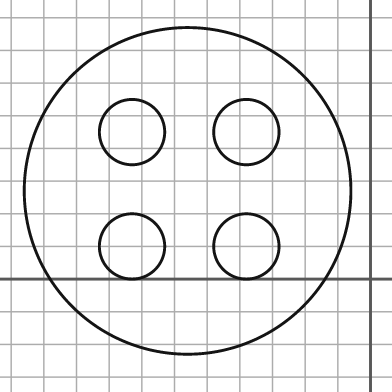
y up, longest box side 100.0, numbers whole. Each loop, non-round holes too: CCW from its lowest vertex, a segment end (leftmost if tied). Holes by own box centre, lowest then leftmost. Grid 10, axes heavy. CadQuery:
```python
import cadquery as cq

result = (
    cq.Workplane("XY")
    .moveTo(-56.0, 27.0)
    .circle(50.0)
    .moveTo(-73.0, 10.0)
    .circle(10.0)
    .moveTo(-38.0, 10.0)
    .circle(10.0)
    .moveTo(-73.0, 45.0)
    .circle(10.0)
    .moveTo(-38.0, 45.0)
    .circle(10.0)
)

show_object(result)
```